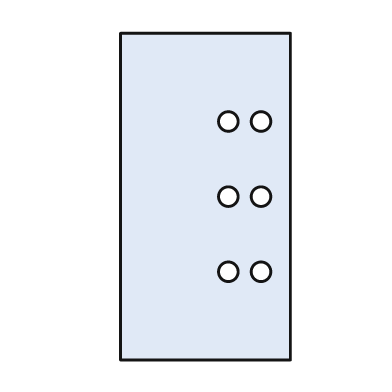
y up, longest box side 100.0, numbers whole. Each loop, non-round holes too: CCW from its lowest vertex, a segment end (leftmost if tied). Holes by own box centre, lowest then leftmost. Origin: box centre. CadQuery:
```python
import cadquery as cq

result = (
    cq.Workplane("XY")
    .moveTo(-26.0, -50.0)
    .lineTo(26.0, -50.0)
    .lineTo(26.0, 50.0)
    .lineTo(-26.0, 50.0)
    .close()
    .moveTo(7.0, -23.0)
    .circle(3.0)
    .moveTo(17.0, -23.0)
    .circle(3.0)
    .moveTo(7.0, 0.0)
    .circle(3.0)
    .moveTo(17.0, 0.0)
    .circle(3.0)
    .moveTo(7.0, 23.0)
    .circle(3.0)
    .moveTo(17.0, 23.0)
    .circle(3.0)
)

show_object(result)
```